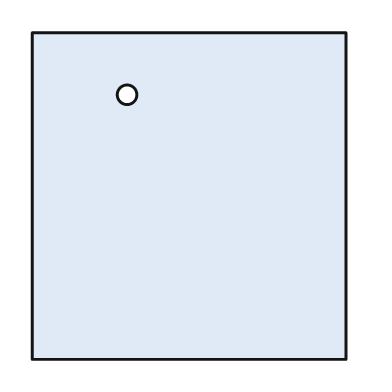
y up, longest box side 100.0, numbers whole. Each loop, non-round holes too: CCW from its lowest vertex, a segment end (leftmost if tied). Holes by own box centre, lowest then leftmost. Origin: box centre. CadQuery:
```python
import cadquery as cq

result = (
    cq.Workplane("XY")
    .moveTo(-48.0, -50.0)
    .lineTo(48.0, -50.0)
    .lineTo(48.0, 50.0)
    .lineTo(-48.0, 50.0)
    .close()
    .moveTo(-19.0, 31.0)
    .circle(3.0)
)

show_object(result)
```